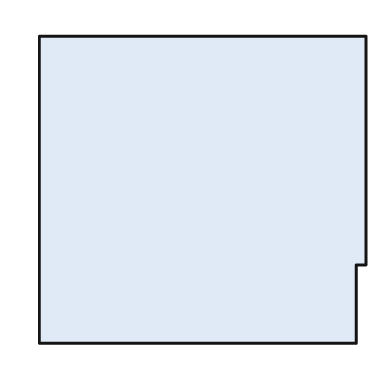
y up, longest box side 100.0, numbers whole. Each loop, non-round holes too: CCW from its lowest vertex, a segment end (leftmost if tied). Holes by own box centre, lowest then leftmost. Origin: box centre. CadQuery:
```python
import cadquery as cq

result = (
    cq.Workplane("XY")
    .moveTo(-50.0, -47.0)
    .lineTo(47.0, -47.0)
    .lineTo(47.0, -23.0)
    .lineTo(50.0, -23.0)
    .lineTo(50.0, 47.0)
    .lineTo(-50.0, 47.0)
    .close()
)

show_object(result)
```